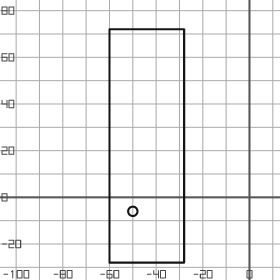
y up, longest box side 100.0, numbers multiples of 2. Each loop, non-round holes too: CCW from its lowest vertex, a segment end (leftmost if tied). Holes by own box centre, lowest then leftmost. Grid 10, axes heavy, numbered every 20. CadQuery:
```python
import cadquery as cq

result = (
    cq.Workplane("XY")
    .moveTo(-60.0, -28.0)
    .lineTo(-28.0, -28.0)
    .lineTo(-28.0, 72.0)
    .lineTo(-60.0, 72.0)
    .close()
    .moveTo(-50.0, -6.0)
    .circle(2.0)
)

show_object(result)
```